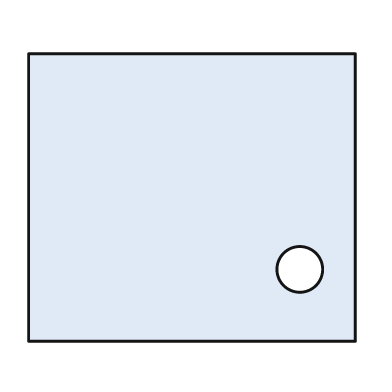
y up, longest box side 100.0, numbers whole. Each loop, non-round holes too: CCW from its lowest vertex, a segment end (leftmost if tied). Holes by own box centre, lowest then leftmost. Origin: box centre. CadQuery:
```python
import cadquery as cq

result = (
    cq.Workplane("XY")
    .moveTo(-50.0, -44.0)
    .lineTo(50.0, -44.0)
    .lineTo(50.0, 44.0)
    .lineTo(-50.0, 44.0)
    .close()
    .moveTo(33.0, -22.0)
    .circle(7.0)
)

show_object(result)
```